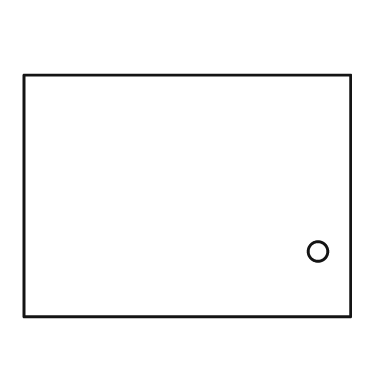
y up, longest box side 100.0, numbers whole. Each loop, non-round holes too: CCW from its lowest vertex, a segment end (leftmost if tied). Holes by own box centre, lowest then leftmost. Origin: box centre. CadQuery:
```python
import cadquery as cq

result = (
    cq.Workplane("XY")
    .moveTo(-50.0, -37.0)
    .lineTo(50.0, -37.0)
    .lineTo(50.0, 37.0)
    .lineTo(-50.0, 37.0)
    .close()
    .moveTo(40.0, -17.0)
    .circle(3.0)
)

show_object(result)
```